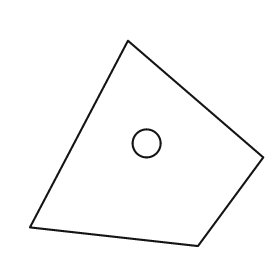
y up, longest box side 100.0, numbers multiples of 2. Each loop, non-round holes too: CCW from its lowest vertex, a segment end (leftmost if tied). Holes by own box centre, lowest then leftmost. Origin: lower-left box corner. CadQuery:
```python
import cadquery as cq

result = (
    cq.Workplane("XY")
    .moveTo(72.0, 0.0)
    .lineTo(100.0, 38.0)
    .lineTo(42.0, 88.0)
    .lineTo(0.0, 8.0)
    .close()
    .moveTo(50.0, 44.0)
    .circle(6.0)
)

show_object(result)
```